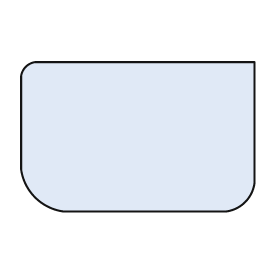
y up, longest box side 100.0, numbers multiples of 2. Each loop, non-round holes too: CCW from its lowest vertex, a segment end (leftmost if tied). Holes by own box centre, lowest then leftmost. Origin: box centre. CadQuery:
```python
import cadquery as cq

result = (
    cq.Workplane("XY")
    .moveTo(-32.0, -32.0)
    .lineTo(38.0, -32.0)
    .threePointArc((46.0, -28.0), (50.0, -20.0))
    .lineTo(50.0, 32.0)
    .lineTo(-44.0, 32.0)
    .threePointArc((-48.0, 30.0), (-50.0, 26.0))
    .lineTo(-50.0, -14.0)
    .threePointArc((-44.0, -26.0), (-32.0, -32.0))
    .close()
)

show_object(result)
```